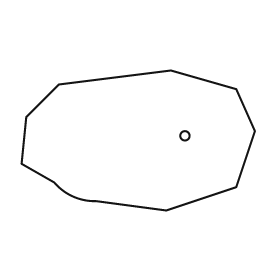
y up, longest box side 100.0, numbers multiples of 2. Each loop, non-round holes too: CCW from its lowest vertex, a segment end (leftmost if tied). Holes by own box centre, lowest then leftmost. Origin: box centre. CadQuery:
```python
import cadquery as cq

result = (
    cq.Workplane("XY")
    .moveTo(12.0, -30.0)
    .lineTo(42.0, -20.0)
    .lineTo(50.0, 4.0)
    .lineTo(42.0, 22.0)
    .lineTo(14.0, 30.0)
    .lineTo(-34.0, 24.0)
    .lineTo(-48.0, 10.0)
    .lineTo(-50.0, -10.0)
    .lineTo(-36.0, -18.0)
    .threePointArc((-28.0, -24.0), (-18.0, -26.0))
    .close()
    .moveTo(20.0, 2.0)
    .circle(2.0)
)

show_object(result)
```